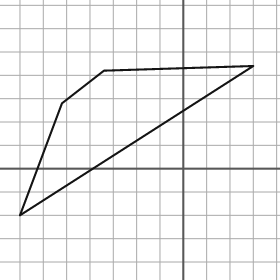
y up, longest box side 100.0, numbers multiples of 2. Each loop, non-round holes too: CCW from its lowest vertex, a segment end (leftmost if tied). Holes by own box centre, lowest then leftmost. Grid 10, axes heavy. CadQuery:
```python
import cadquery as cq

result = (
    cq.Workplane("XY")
    .moveTo(-70.0, -20.0)
    .lineTo(30.0, 44.0)
    .lineTo(-34.0, 42.0)
    .lineTo(-52.0, 28.0)
    .close()
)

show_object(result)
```